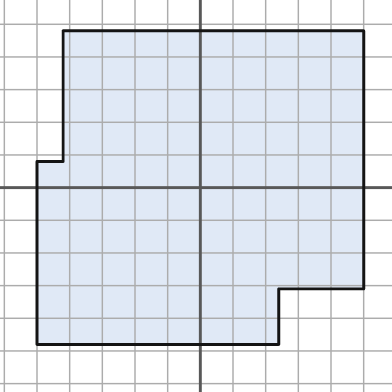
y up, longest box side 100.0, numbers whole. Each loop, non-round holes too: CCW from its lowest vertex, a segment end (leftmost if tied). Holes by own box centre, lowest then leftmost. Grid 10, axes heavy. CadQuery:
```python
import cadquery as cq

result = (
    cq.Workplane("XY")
    .moveTo(-50.0, -48.0)
    .lineTo(24.0, -48.0)
    .lineTo(24.0, -31.0)
    .lineTo(50.0, -31.0)
    .lineTo(50.0, 48.0)
    .lineTo(-42.0, 48.0)
    .lineTo(-42.0, 8.0)
    .lineTo(-50.0, 8.0)
    .close()
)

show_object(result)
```